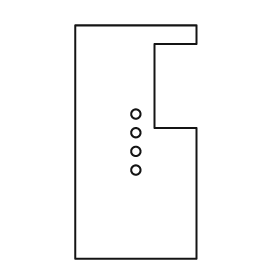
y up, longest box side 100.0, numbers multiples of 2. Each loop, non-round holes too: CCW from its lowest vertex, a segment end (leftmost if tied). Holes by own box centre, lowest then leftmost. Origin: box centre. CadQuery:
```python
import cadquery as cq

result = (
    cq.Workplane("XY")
    .moveTo(-26.0, -50.0)
    .lineTo(26.0, -50.0)
    .lineTo(26.0, 6.0)
    .lineTo(8.0, 6.0)
    .lineTo(8.0, 42.0)
    .lineTo(26.0, 42.0)
    .lineTo(26.0, 50.0)
    .lineTo(-26.0, 50.0)
    .close()
    .moveTo(0.0, -12.0)
    .circle(2.0)
    .moveTo(0.0, -4.0)
    .circle(2.0)
    .moveTo(0.0, 4.0)
    .circle(2.0)
    .moveTo(0.0, 12.0)
    .circle(2.0)
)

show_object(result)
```